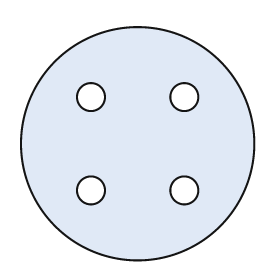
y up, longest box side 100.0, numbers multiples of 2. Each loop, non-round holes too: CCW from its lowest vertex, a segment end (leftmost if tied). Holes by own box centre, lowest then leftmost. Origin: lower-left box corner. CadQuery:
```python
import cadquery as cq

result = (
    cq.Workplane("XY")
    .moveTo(50.0, 50.0)
    .circle(50.0)
    .moveTo(30.0, 30.0)
    .circle(6.0)
    .moveTo(70.0, 30.0)
    .circle(6.0)
    .moveTo(30.0, 70.0)
    .circle(6.0)
    .moveTo(70.0, 70.0)
    .circle(6.0)
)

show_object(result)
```